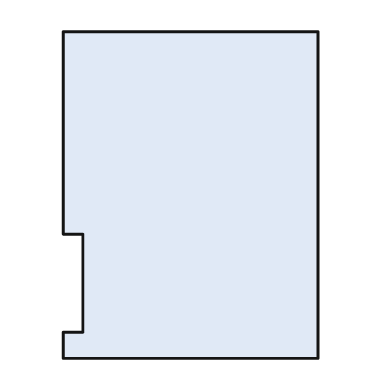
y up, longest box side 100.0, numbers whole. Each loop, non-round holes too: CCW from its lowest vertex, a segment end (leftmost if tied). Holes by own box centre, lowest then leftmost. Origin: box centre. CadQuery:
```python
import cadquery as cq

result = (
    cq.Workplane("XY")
    .moveTo(-39.0, -50.0)
    .lineTo(39.0, -50.0)
    .lineTo(39.0, 50.0)
    .lineTo(-39.0, 50.0)
    .lineTo(-39.0, -12.0)
    .lineTo(-33.0, -12.0)
    .lineTo(-33.0, -42.0)
    .lineTo(-39.0, -42.0)
    .close()
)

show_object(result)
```